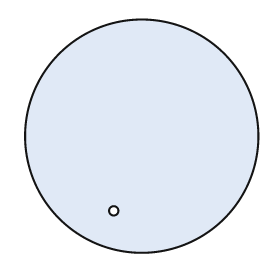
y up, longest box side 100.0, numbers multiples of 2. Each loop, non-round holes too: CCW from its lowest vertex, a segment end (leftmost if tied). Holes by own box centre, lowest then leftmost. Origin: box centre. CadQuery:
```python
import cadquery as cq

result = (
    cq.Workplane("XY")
    .moveTo(0.0, 0.0)
    .circle(50.0)
    .moveTo(-12.0, -32.0)
    .circle(2.0)
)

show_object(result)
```